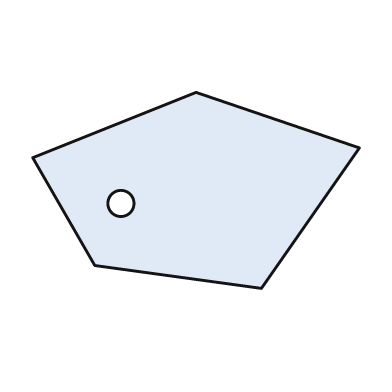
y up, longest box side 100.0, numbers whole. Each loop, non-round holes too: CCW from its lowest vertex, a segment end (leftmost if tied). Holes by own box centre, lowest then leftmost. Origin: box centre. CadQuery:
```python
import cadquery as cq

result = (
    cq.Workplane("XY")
    .moveTo(20.0, -30.0)
    .lineTo(50.0, 13.0)
    .lineTo(0.0, 30.0)
    .lineTo(-50.0, 10.0)
    .lineTo(-31.0, -23.0)
    .close()
    .moveTo(-23.0, -4.0)
    .circle(4.0)
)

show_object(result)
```